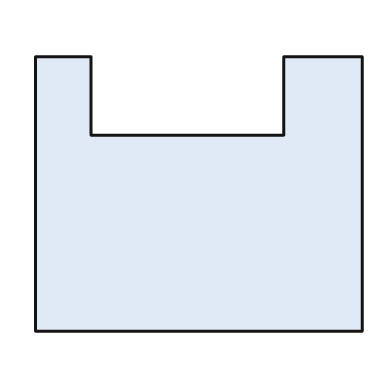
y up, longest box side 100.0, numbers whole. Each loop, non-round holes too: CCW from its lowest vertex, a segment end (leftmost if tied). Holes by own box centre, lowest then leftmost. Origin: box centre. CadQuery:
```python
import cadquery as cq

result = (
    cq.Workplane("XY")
    .moveTo(-50.0, -42.0)
    .lineTo(50.0, -42.0)
    .lineTo(50.0, 42.0)
    .lineTo(26.0, 42.0)
    .lineTo(26.0, 18.0)
    .lineTo(-33.0, 18.0)
    .lineTo(-33.0, 42.0)
    .lineTo(-50.0, 42.0)
    .close()
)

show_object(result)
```